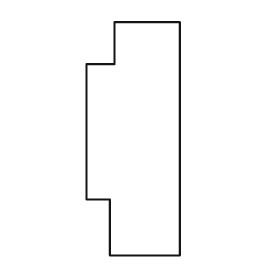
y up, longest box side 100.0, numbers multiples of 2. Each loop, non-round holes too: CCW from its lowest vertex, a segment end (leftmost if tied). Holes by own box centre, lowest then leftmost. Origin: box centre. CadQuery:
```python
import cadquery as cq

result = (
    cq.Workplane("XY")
    .moveTo(-10.0, -50.0)
    .lineTo(20.0, -50.0)
    .lineTo(20.0, 50.0)
    .lineTo(-8.0, 50.0)
    .lineTo(-8.0, 32.0)
    .lineTo(-20.0, 32.0)
    .lineTo(-20.0, -26.0)
    .lineTo(-10.0, -26.0)
    .close()
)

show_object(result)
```